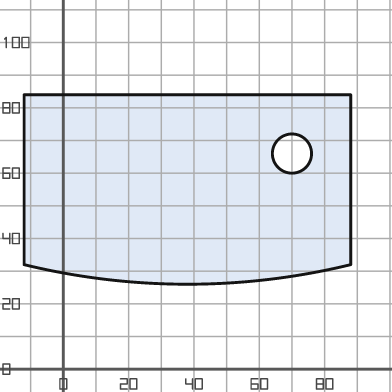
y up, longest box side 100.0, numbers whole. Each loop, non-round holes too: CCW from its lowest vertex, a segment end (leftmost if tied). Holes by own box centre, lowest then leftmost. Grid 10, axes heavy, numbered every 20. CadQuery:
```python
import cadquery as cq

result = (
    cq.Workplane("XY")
    .moveTo(-12.0, 32.0)
    .threePointArc((38.0, 26.0), (88.0, 32.0))
    .lineTo(88.0, 84.0)
    .lineTo(-12.0, 84.0)
    .close()
    .moveTo(70.0, 66.0)
    .circle(6.0)
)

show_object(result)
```